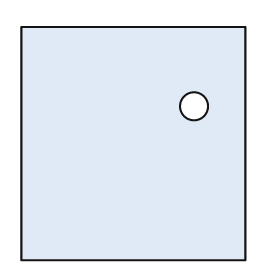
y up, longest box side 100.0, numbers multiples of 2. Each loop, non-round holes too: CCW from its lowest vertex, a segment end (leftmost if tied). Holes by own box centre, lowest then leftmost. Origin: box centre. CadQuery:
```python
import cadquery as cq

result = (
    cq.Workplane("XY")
    .moveTo(-48.0, -50.0)
    .lineTo(48.0, -50.0)
    .lineTo(48.0, 50.0)
    .lineTo(-48.0, 50.0)
    .close()
    .moveTo(26.0, 16.0)
    .circle(6.0)
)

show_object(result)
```